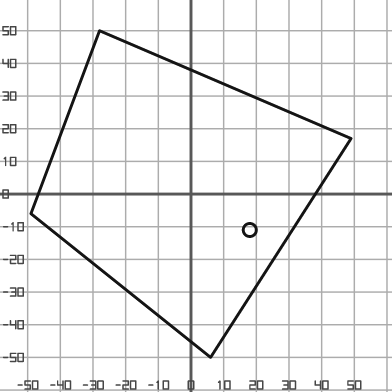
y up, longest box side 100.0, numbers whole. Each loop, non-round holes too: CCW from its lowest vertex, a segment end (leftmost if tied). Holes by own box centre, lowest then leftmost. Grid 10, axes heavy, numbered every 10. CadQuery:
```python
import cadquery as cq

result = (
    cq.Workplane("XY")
    .moveTo(6.0, -50.0)
    .lineTo(49.0, 17.0)
    .lineTo(-28.0, 50.0)
    .lineTo(-49.0, -6.0)
    .close()
    .moveTo(18.0, -11.0)
    .circle(2.0)
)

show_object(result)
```